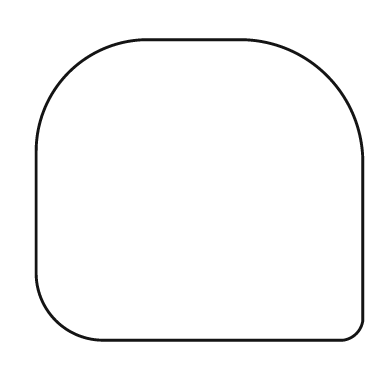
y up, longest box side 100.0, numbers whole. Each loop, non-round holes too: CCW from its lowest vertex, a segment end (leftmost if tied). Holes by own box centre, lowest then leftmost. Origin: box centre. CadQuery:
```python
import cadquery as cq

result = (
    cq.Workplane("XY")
    .moveTo(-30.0, -46.0)
    .lineTo(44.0, -46.0)
    .threePointArc((48.0, -44.0), (50.0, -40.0))
    .lineTo(50.0, 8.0)
    .threePointArc((39.0, 35.0), (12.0, 46.0))
    .lineTo(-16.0, 46.0)
    .threePointArc((-40.0, 36.0), (-50.0, 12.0))
    .lineTo(-50.0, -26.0)
    .threePointArc((-44.0, -40.0), (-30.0, -46.0))
    .close()
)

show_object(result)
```